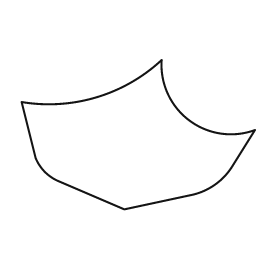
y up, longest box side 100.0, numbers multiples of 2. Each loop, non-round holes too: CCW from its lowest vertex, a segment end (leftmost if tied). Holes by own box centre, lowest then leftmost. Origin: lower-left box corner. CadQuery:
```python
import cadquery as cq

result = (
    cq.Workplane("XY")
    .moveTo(44.0, 0.0)
    .lineTo(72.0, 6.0)
    .threePointArc((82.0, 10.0), (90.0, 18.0))
    .lineTo(100.0, 34.0)
    .threePointArc((72.0, 38.0), (60.0, 64.0))
    .threePointArc((32.0, 48.0), (0.0, 46.0))
    .lineTo(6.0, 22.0)
    .threePointArc((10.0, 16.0), (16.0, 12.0))
    .close()
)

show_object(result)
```